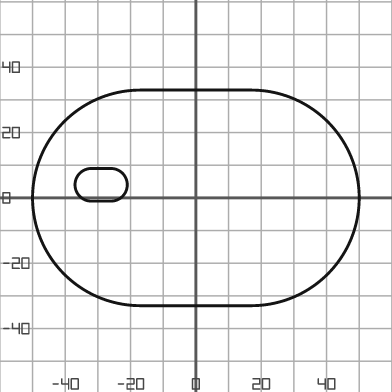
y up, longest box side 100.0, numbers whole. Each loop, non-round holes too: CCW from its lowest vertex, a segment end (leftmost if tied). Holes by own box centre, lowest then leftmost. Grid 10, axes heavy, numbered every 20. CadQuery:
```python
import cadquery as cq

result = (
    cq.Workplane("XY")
    .moveTo(-17.0, -33.0)
    .lineTo(17.0, -33.0)
    .threePointArc((50.0, 0.0), (17.0, 33.0))
    .lineTo(-17.0, 33.0)
    .threePointArc((-50.0, 0.0), (-17.0, -33.0))
    .close()
    .moveTo(-32.0, -1.0)
    .lineTo(-26.0, -1.0)
    .threePointArc((-21.0, 4.0), (-26.0, 9.0))
    .lineTo(-32.0, 9.0)
    .threePointArc((-37.0, 4.0), (-32.0, -1.0))
    .close()
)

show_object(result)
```